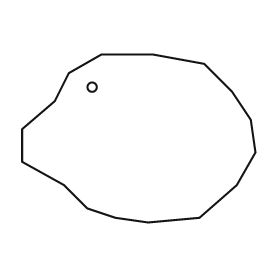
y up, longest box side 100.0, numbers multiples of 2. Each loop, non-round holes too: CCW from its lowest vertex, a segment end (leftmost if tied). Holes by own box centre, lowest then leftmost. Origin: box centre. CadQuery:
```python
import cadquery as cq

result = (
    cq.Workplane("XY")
    .moveTo(4.0, -36.0)
    .lineTo(26.0, -34.0)
    .lineTo(42.0, -20.0)
    .lineTo(50.0, -6.0)
    .lineTo(48.0, 8.0)
    .lineTo(40.0, 20.0)
    .lineTo(28.0, 32.0)
    .lineTo(6.0, 36.0)
    .lineTo(-16.0, 36.0)
    .lineTo(-30.0, 28.0)
    .lineTo(-36.0, 16.0)
    .lineTo(-50.0, 4.0)
    .lineTo(-50.0, -10.0)
    .lineTo(-32.0, -20.0)
    .lineTo(-22.0, -30.0)
    .lineTo(-10.0, -34.0)
    .close()
    .moveTo(-20.0, 22.0)
    .circle(2.0)
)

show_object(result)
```